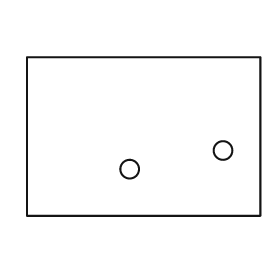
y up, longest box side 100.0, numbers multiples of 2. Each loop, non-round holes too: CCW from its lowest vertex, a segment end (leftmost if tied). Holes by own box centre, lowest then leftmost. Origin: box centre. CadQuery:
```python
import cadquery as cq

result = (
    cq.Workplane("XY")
    .moveTo(-50.0, -34.0)
    .lineTo(50.0, -34.0)
    .lineTo(50.0, 34.0)
    .lineTo(-50.0, 34.0)
    .close()
    .moveTo(-6.0, -14.0)
    .circle(4.0)
    .moveTo(34.0, -6.0)
    .circle(4.0)
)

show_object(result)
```